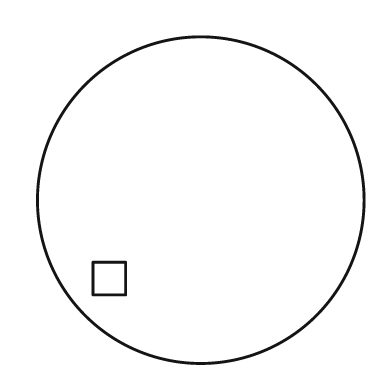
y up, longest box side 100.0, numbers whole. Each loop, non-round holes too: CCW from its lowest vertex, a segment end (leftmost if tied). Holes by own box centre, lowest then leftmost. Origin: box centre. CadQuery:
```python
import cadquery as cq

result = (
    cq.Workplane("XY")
    .moveTo(0.0, 0.0)
    .circle(50.0)
    .moveTo(-33.0, -29.0)
    .lineTo(-23.0, -29.0)
    .lineTo(-23.0, -19.0)
    .lineTo(-33.0, -19.0)
    .close()
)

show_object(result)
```